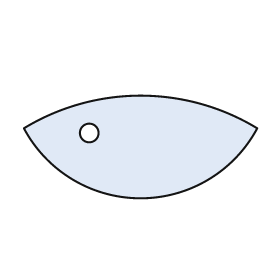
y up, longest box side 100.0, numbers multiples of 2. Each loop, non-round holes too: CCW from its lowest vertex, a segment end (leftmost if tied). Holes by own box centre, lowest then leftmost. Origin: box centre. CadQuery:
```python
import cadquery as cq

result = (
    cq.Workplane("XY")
    .moveTo(-50.0, 8.0)
    .threePointArc((0.0, -22.0), (50.0, 8.0))
    .threePointArc((0.0, 22.0), (-50.0, 8.0))
    .close()
    .moveTo(-22.0, 6.0)
    .circle(4.0)
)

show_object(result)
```